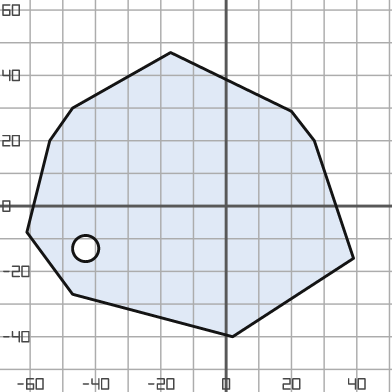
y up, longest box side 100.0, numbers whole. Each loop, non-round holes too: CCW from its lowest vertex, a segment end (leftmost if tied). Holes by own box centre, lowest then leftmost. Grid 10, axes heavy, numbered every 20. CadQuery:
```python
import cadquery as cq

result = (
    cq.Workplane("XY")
    .moveTo(2.0, -40.0)
    .lineTo(39.0, -16.0)
    .lineTo(27.0, 20.0)
    .lineTo(20.0, 29.0)
    .lineTo(-17.0, 47.0)
    .lineTo(-47.0, 30.0)
    .lineTo(-54.0, 20.0)
    .lineTo(-61.0, -8.0)
    .lineTo(-47.0, -27.0)
    .close()
    .moveTo(-43.0, -13.0)
    .circle(4.0)
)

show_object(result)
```